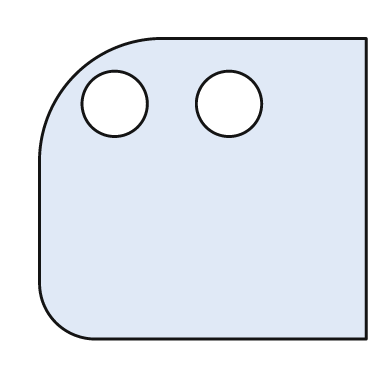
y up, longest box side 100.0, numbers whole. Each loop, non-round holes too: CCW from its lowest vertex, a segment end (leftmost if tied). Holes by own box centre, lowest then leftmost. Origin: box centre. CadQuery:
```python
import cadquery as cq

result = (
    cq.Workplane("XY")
    .moveTo(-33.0, -46.0)
    .lineTo(50.0, -46.0)
    .lineTo(50.0, 46.0)
    .lineTo(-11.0, 46.0)
    .threePointArc((-39.0, 35.0), (-50.0, 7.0))
    .lineTo(-50.0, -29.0)
    .threePointArc((-45.0, -41.0), (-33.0, -46.0))
    .close()
    .moveTo(-27.0, 26.0)
    .circle(10.0)
    .moveTo(8.0, 26.0)
    .circle(10.0)
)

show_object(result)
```